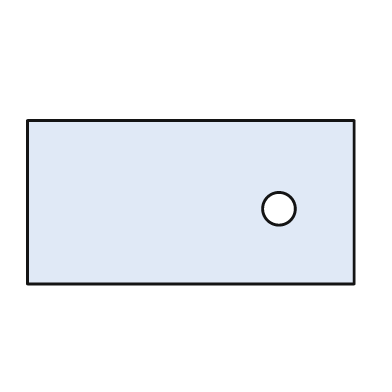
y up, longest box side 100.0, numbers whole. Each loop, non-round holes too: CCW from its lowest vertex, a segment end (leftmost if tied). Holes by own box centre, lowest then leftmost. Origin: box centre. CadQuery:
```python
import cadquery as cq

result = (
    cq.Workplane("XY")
    .moveTo(-50.0, -25.0)
    .lineTo(50.0, -25.0)
    .lineTo(50.0, 25.0)
    .lineTo(-50.0, 25.0)
    .close()
    .moveTo(27.0, -2.0)
    .circle(5.0)
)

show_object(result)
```